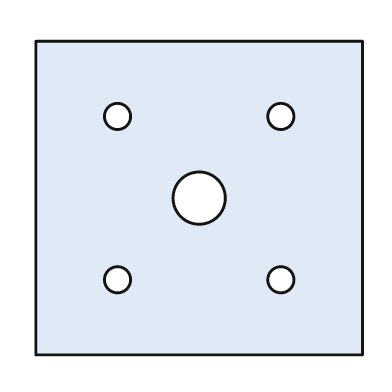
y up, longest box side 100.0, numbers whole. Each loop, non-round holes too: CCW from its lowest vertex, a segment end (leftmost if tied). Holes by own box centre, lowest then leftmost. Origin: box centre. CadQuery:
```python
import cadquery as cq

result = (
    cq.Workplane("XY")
    .moveTo(-50.0, -48.0)
    .lineTo(50.0, -48.0)
    .lineTo(50.0, 48.0)
    .lineTo(-50.0, 48.0)
    .close()
    .moveTo(-25.0, -25.0)
    .circle(4.0)
    .moveTo(25.0, -25.0)
    .circle(4.0)
    .moveTo(0.0, 0.0)
    .circle(8.0)
    .moveTo(-25.0, 25.0)
    .circle(4.0)
    .moveTo(25.0, 25.0)
    .circle(4.0)
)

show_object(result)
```